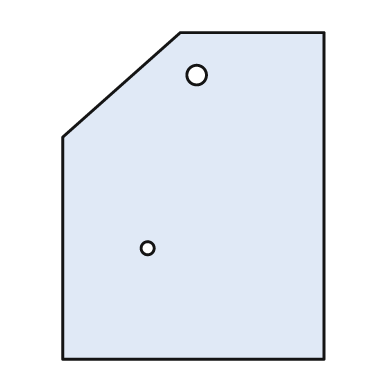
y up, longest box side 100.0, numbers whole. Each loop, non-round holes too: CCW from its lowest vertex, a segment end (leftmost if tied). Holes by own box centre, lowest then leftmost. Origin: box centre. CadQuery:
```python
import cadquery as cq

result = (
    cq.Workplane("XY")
    .moveTo(-40.0, -50.0)
    .lineTo(40.0, -50.0)
    .lineTo(40.0, 50.0)
    .lineTo(-4.0, 50.0)
    .lineTo(-40.0, 18.0)
    .close()
    .moveTo(-14.0, -16.0)
    .circle(2.0)
    .moveTo(1.0, 37.0)
    .circle(3.0)
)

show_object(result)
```